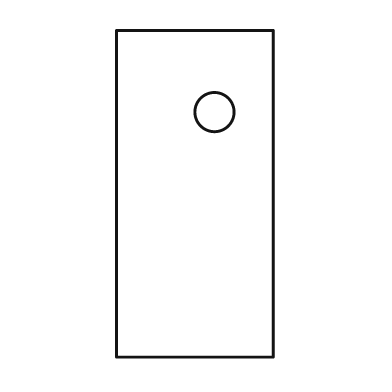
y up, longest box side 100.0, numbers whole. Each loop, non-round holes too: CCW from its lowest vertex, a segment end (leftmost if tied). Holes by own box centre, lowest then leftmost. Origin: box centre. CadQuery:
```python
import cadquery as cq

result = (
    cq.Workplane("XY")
    .moveTo(-24.0, -50.0)
    .lineTo(24.0, -50.0)
    .lineTo(24.0, 50.0)
    .lineTo(-24.0, 50.0)
    .close()
    .moveTo(6.0, 25.0)
    .circle(6.0)
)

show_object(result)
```